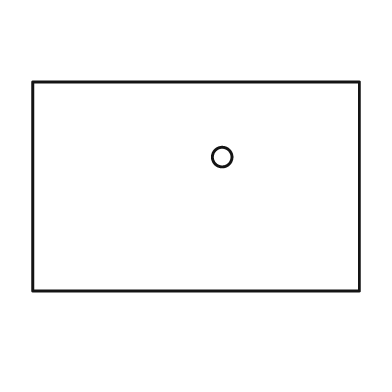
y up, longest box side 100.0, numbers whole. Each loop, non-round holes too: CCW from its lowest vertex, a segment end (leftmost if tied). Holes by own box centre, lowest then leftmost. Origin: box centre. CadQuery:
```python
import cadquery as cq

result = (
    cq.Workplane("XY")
    .moveTo(-50.0, -32.0)
    .lineTo(50.0, -32.0)
    .lineTo(50.0, 32.0)
    .lineTo(-50.0, 32.0)
    .close()
    .moveTo(8.0, 9.0)
    .circle(3.0)
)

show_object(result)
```